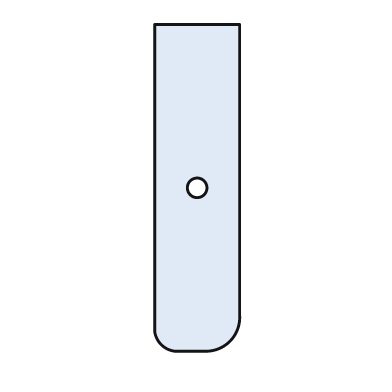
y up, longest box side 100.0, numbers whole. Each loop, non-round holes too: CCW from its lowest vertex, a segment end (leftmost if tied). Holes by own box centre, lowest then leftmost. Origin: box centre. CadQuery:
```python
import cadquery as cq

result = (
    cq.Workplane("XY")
    .moveTo(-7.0, -50.0)
    .lineTo(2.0, -50.0)
    .threePointArc((10.0, -47.0), (13.0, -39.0))
    .lineTo(13.0, 50.0)
    .lineTo(-13.0, 50.0)
    .lineTo(-13.0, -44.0)
    .threePointArc((-11.0, -48.0), (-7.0, -50.0))
    .close()
    .moveTo(0.0, 0.0)
    .circle(3.0)
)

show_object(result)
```